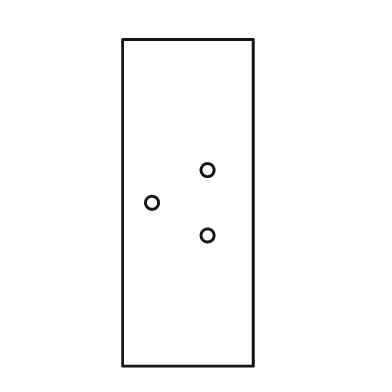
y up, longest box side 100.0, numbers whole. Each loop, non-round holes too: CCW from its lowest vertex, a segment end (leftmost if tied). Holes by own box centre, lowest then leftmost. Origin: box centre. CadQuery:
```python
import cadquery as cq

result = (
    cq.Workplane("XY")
    .moveTo(-20.0, -50.0)
    .lineTo(20.0, -50.0)
    .lineTo(20.0, 50.0)
    .lineTo(-20.0, 50.0)
    .close()
    .moveTo(6.0, -10.0)
    .circle(2.0)
    .moveTo(-11.0, 0.0)
    .circle(2.0)
    .moveTo(6.0, 10.0)
    .circle(2.0)
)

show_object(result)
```